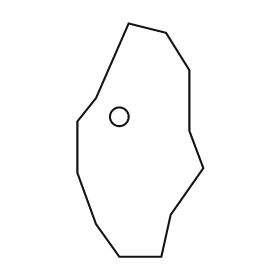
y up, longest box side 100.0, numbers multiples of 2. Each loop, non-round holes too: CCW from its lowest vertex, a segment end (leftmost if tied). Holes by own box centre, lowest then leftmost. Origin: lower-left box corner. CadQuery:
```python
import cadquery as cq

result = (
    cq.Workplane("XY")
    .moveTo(18.0, 0.0)
    .lineTo(36.0, 0.0)
    .lineTo(40.0, 18.0)
    .lineTo(54.0, 38.0)
    .lineTo(48.0, 54.0)
    .lineTo(48.0, 80.0)
    .lineTo(38.0, 96.0)
    .lineTo(22.0, 100.0)
    .lineTo(8.0, 68.0)
    .lineTo(0.0, 58.0)
    .lineTo(0.0, 36.0)
    .lineTo(8.0, 14.0)
    .close()
    .moveTo(18.0, 60.0)
    .circle(4.0)
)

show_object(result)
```